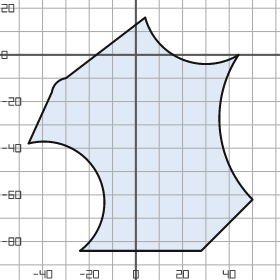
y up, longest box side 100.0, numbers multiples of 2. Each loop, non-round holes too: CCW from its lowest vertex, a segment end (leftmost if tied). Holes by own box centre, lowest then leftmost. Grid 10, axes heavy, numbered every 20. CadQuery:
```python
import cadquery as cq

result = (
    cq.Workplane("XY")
    .moveTo(-24.0, -84.0)
    .lineTo(28.0, -84.0)
    .lineTo(50.0, -62.0)
    .threePointArc((36.0, -32.0), (44.0, 0.0))
    .threePointArc((20.0, -2.0), (4.0, 16.0))
    .lineTo(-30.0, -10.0)
    .threePointArc((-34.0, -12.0), (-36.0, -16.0))
    .lineTo(-46.0, -38.0)
    .threePointArc((-16.0, -52.0), (-24.0, -84.0))
    .close()
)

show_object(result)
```